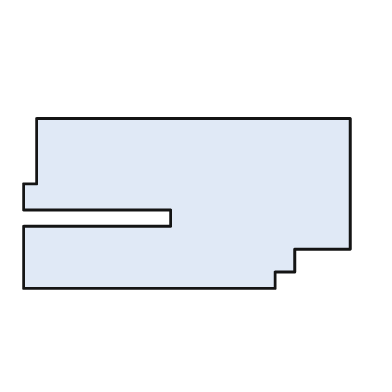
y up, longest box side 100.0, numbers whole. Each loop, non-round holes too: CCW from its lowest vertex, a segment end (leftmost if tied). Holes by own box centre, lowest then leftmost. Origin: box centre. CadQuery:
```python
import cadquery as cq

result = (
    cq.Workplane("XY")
    .moveTo(-50.0, -26.0)
    .lineTo(27.0, -26.0)
    .lineTo(27.0, -21.0)
    .lineTo(33.0, -21.0)
    .lineTo(33.0, -14.0)
    .lineTo(50.0, -14.0)
    .lineTo(50.0, 26.0)
    .lineTo(-46.0, 26.0)
    .lineTo(-46.0, 6.0)
    .lineTo(-50.0, 6.0)
    .lineTo(-50.0, -2.0)
    .lineTo(-5.0, -2.0)
    .lineTo(-5.0, -7.0)
    .lineTo(-50.0, -7.0)
    .close()
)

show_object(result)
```